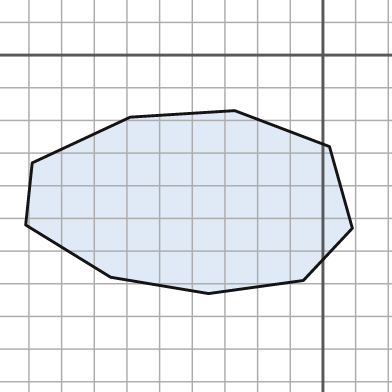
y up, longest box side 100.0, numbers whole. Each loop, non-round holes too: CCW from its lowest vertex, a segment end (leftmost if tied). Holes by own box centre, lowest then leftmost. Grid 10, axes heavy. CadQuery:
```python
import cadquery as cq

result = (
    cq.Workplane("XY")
    .moveTo(-35.0, -73.0)
    .lineTo(-6.0, -69.0)
    .lineTo(9.0, -53.0)
    .lineTo(2.0, -28.0)
    .lineTo(-27.0, -17.0)
    .lineTo(-59.0, -19.0)
    .lineTo(-89.0, -33.0)
    .lineTo(-91.0, -52.0)
    .lineTo(-65.0, -68.0)
    .close()
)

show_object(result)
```